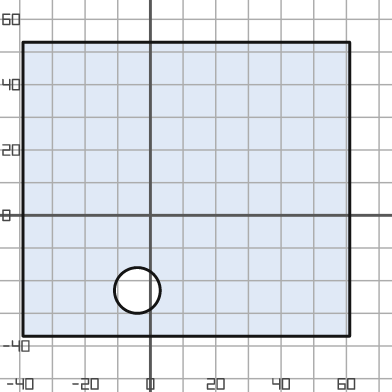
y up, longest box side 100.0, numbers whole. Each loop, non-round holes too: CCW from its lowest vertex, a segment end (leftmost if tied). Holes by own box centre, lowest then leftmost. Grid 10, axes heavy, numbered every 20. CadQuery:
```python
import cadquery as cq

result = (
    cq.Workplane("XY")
    .moveTo(-39.0, -37.0)
    .lineTo(61.0, -37.0)
    .lineTo(61.0, 53.0)
    .lineTo(-39.0, 53.0)
    .close()
    .moveTo(-4.0, -23.0)
    .circle(7.0)
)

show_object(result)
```